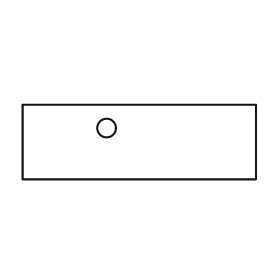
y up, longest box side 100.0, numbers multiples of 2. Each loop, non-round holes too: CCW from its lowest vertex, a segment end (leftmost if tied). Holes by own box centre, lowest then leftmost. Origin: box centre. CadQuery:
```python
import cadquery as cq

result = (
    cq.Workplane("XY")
    .moveTo(-50.0, -16.0)
    .lineTo(50.0, -16.0)
    .lineTo(50.0, 16.0)
    .lineTo(-50.0, 16.0)
    .close()
    .moveTo(-14.0, 6.0)
    .circle(4.0)
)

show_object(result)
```